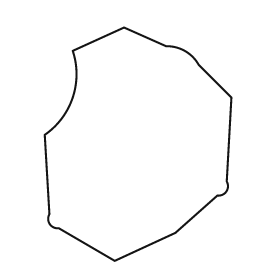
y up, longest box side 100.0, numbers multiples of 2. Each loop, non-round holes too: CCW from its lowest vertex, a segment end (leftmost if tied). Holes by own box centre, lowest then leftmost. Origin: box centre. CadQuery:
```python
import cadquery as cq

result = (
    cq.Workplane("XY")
    .moveTo(-10.0, -50.0)
    .lineTo(16.0, -38.0)
    .lineTo(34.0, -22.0)
    .threePointArc((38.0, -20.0), (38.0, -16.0))
    .lineTo(40.0, 20.0)
    .lineTo(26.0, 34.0)
    .threePointArc((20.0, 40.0), (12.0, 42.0))
    .lineTo(-6.0, 50.0)
    .lineTo(-28.0, 40.0)
    .threePointArc((-28.0, 20.0), (-40.0, 4.0))
    .lineTo(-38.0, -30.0)
    .threePointArc((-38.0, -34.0), (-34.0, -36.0))
    .close()
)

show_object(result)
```